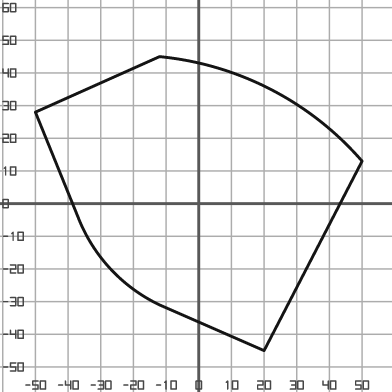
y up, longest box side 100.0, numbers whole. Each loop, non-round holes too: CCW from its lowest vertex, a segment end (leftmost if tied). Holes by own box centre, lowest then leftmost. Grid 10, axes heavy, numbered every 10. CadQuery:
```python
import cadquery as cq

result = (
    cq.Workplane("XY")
    .moveTo(20.0, -45.0)
    .lineTo(50.0, 13.0)
    .threePointArc((22.0, 35.0), (-12.0, 45.0))
    .lineTo(-50.0, 28.0)
    .lineTo(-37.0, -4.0)
    .threePointArc((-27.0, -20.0), (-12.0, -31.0))
    .close()
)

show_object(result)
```